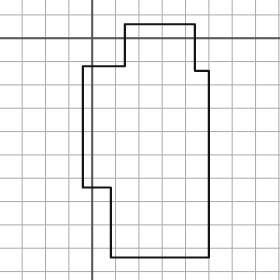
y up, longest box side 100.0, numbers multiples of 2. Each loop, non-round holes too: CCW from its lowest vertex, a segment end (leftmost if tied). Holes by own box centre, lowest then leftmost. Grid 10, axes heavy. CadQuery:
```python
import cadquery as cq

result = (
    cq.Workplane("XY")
    .moveTo(8.0, -94.0)
    .lineTo(50.0, -94.0)
    .lineTo(50.0, -14.0)
    .lineTo(44.0, -14.0)
    .lineTo(44.0, 6.0)
    .lineTo(14.0, 6.0)
    .lineTo(14.0, -12.0)
    .lineTo(-4.0, -12.0)
    .lineTo(-4.0, -64.0)
    .lineTo(8.0, -64.0)
    .close()
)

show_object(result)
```